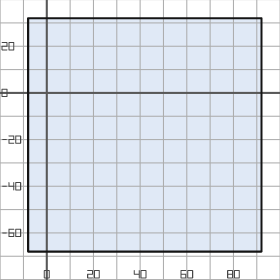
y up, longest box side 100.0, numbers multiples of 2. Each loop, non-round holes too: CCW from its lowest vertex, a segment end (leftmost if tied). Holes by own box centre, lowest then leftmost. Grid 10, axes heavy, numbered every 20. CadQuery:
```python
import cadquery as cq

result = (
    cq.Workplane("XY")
    .moveTo(-8.0, -68.0)
    .lineTo(92.0, -68.0)
    .lineTo(92.0, 32.0)
    .lineTo(-8.0, 32.0)
    .close()
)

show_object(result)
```